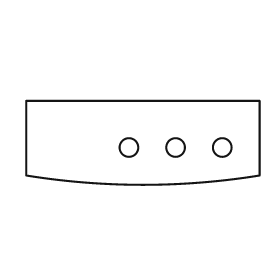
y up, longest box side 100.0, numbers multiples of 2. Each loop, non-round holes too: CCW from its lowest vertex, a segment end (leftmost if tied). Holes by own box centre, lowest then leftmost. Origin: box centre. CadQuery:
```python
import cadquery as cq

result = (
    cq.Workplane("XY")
    .moveTo(-50.0, -14.0)
    .threePointArc((0.0, -18.0), (50.0, -14.0))
    .lineTo(50.0, 18.0)
    .lineTo(-50.0, 18.0)
    .close()
    .moveTo(-6.0, -2.0)
    .circle(4.0)
    .moveTo(14.0, -2.0)
    .circle(4.0)
    .moveTo(34.0, -2.0)
    .circle(4.0)
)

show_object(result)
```